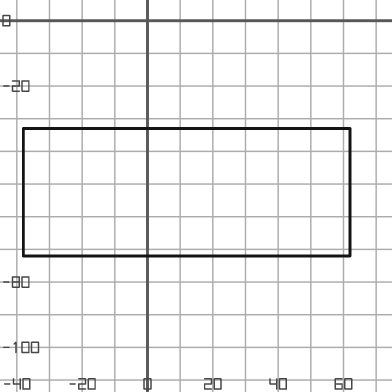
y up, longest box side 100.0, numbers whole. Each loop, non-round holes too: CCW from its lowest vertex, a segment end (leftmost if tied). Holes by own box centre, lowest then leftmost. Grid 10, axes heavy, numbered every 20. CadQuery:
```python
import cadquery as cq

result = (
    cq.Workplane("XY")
    .moveTo(-38.0, -72.0)
    .lineTo(62.0, -72.0)
    .lineTo(62.0, -33.0)
    .lineTo(-38.0, -33.0)
    .close()
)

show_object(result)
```